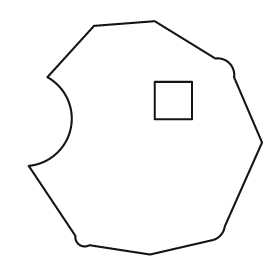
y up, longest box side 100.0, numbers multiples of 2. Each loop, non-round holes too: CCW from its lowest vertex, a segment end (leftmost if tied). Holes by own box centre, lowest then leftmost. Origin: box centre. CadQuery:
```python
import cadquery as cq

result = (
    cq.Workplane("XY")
    .moveTo(2.0, -50.0)
    .lineTo(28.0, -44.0)
    .threePointArc((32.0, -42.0), (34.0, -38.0))
    .lineTo(50.0, -2.0)
    .lineTo(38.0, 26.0)
    .threePointArc((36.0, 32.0), (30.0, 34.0))
    .lineTo(4.0, 50.0)
    .lineTo(-22.0, 48.0)
    .lineTo(-42.0, 26.0)
    .threePointArc((-32.0, 4.0), (-50.0, -12.0))
    .lineTo(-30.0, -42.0)
    .threePointArc((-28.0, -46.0), (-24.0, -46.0))
    .close()
    .moveTo(4.0, 8.0)
    .lineTo(20.0, 8.0)
    .lineTo(20.0, 24.0)
    .lineTo(4.0, 24.0)
    .close()
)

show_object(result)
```